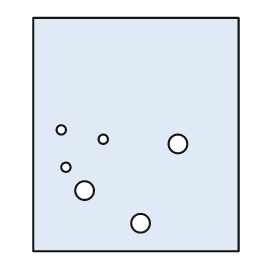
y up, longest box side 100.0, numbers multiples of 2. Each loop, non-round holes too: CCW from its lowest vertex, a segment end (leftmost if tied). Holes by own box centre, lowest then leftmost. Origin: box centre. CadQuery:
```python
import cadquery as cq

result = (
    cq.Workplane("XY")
    .moveTo(-44.0, -50.0)
    .lineTo(44.0, -50.0)
    .lineTo(44.0, 50.0)
    .lineTo(-44.0, 50.0)
    .close()
    .moveTo(2.0, -38.0)
    .circle(4.0)
    .moveTo(-22.0, -24.0)
    .circle(4.0)
    .moveTo(-30.0, -14.0)
    .circle(2.0)
    .moveTo(18.0, -4.0)
    .circle(4.0)
    .moveTo(-14.0, -2.0)
    .circle(2.0)
    .moveTo(-32.0, 2.0)
    .circle(2.0)
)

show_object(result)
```